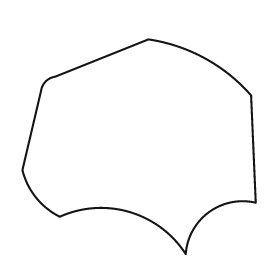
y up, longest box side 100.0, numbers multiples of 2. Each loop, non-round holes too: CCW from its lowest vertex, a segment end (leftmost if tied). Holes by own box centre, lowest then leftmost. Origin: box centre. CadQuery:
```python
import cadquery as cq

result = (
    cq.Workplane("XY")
    .moveTo(20.0, -46.0)
    .threePointArc((30.0, -28.0), (50.0, -24.0))
    .lineTo(48.0, 22.0)
    .threePointArc((28.0, 38.0), (4.0, 46.0))
    .lineTo(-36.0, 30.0)
    .threePointArc((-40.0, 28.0), (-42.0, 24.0))
    .lineTo(-50.0, -10.0)
    .threePointArc((-44.0, -22.0), (-34.0, -30.0))
    .threePointArc((-4.0, -28.0), (20.0, -46.0))
    .close()
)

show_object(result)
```